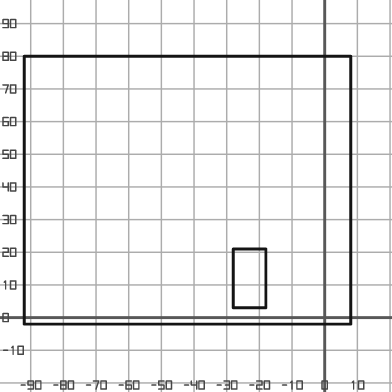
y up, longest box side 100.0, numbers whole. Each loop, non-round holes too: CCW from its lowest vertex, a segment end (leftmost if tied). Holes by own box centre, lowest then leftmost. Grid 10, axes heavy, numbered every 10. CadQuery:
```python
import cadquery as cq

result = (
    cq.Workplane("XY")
    .moveTo(-92.0, -2.0)
    .lineTo(8.0, -2.0)
    .lineTo(8.0, 80.0)
    .lineTo(-92.0, 80.0)
    .close()
    .moveTo(-28.0, 3.0)
    .lineTo(-18.0, 3.0)
    .lineTo(-18.0, 21.0)
    .lineTo(-28.0, 21.0)
    .close()
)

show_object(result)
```